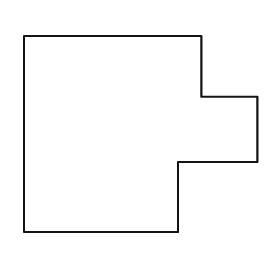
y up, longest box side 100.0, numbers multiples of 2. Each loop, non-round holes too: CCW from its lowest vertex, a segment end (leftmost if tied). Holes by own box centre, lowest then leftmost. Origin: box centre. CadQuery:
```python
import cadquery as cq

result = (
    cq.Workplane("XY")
    .moveTo(-50.0, -42.0)
    .lineTo(16.0, -42.0)
    .lineTo(16.0, -12.0)
    .lineTo(50.0, -12.0)
    .lineTo(50.0, 16.0)
    .lineTo(26.0, 16.0)
    .lineTo(26.0, 42.0)
    .lineTo(-50.0, 42.0)
    .close()
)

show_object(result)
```